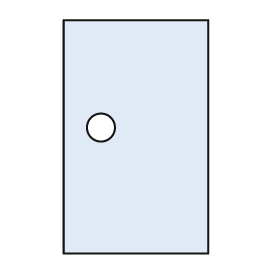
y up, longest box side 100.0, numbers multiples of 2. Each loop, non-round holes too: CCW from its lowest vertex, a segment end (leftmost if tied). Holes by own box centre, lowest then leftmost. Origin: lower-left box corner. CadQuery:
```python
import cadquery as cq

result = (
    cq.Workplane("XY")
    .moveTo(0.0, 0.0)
    .lineTo(62.0, 0.0)
    .lineTo(62.0, 100.0)
    .lineTo(0.0, 100.0)
    .close()
    .moveTo(16.0, 54.0)
    .circle(6.0)
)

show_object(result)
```